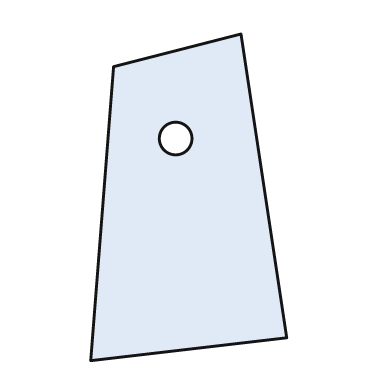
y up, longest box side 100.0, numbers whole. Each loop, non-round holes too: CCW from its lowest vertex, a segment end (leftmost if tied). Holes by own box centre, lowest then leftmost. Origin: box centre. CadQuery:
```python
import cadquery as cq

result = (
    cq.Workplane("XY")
    .moveTo(-30.0, -50.0)
    .lineTo(30.0, -43.0)
    .lineTo(16.0, 50.0)
    .lineTo(-23.0, 40.0)
    .close()
    .moveTo(-4.0, 18.0)
    .circle(5.0)
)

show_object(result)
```